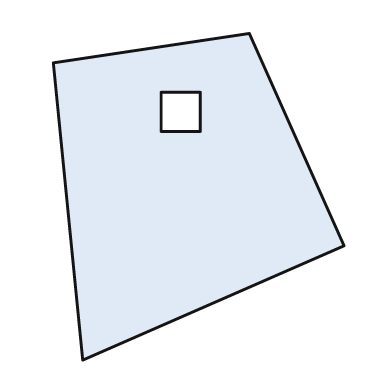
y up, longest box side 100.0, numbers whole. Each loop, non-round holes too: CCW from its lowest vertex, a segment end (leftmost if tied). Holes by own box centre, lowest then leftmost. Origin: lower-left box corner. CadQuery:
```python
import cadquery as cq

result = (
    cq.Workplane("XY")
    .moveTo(9.0, 0.0)
    .lineTo(89.0, 35.0)
    .lineTo(60.0, 100.0)
    .lineTo(0.0, 91.0)
    .close()
    .moveTo(33.0, 70.0)
    .lineTo(45.0, 70.0)
    .lineTo(45.0, 82.0)
    .lineTo(33.0, 82.0)
    .close()
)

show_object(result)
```